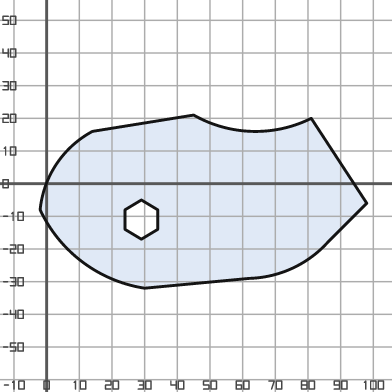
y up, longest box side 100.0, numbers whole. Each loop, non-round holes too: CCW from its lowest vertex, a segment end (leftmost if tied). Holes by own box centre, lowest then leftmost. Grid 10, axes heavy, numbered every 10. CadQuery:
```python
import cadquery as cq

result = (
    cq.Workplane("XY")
    .moveTo(30.0, -32.0)
    .lineTo(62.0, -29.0)
    .threePointArc((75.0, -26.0), (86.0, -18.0))
    .lineTo(98.0, -6.0)
    .lineTo(81.0, 20.0)
    .threePointArc((63.0, 16.0), (45.0, 21.0))
    .lineTo(14.0, 16.0)
    .threePointArc((3.0, 6.0), (-2.0, -8.0))
    .threePointArc((11.0, -24.0), (30.0, -32.0))
    .close()
    .moveTo(29.0, -17.0)
    .lineTo(34.0, -14.0)
    .lineTo(34.0, -8.0)
    .lineTo(29.0, -5.0)
    .lineTo(24.0, -8.0)
    .lineTo(24.0, -14.0)
    .close()
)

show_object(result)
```